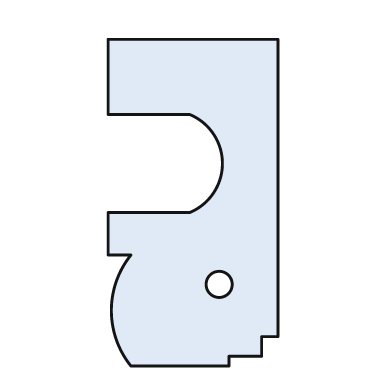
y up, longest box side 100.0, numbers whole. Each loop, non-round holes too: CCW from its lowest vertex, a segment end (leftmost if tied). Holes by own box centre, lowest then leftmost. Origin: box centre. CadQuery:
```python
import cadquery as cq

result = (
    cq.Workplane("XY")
    .moveTo(-19.0, -50.0)
    .lineTo(11.0, -50.0)
    .lineTo(11.0, -47.0)
    .lineTo(21.0, -47.0)
    .lineTo(21.0, -41.0)
    .lineTo(26.0, -41.0)
    .lineTo(26.0, 50.0)
    .lineTo(-26.0, 50.0)
    .lineTo(-26.0, 27.0)
    .lineTo(-1.0, 27.0)
    .threePointArc((9.0, 12.0), (-1.0, -3.0))
    .lineTo(-26.0, -3.0)
    .lineTo(-26.0, -16.0)
    .lineTo(-19.0, -16.0)
    .threePointArc((-25.0, -33.0), (-19.0, -50.0))
    .close()
    .moveTo(8.0, -25.0)
    .circle(4.0)
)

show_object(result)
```